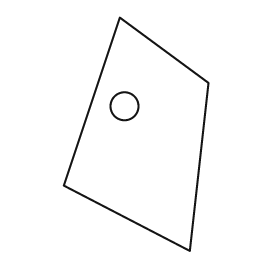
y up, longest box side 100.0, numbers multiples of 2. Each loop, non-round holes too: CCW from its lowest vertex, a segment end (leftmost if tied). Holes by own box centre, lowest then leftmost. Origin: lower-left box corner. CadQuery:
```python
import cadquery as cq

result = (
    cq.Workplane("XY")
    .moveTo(54.0, 0.0)
    .lineTo(62.0, 72.0)
    .lineTo(24.0, 100.0)
    .lineTo(0.0, 28.0)
    .close()
    .moveTo(26.0, 62.0)
    .circle(6.0)
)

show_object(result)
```